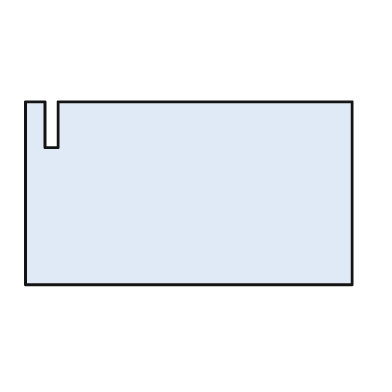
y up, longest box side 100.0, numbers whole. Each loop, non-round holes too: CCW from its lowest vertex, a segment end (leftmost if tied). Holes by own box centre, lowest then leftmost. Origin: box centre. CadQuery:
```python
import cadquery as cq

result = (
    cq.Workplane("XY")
    .moveTo(-50.0, -28.0)
    .lineTo(50.0, -28.0)
    .lineTo(50.0, 28.0)
    .lineTo(-40.0, 28.0)
    .lineTo(-40.0, 14.0)
    .lineTo(-44.0, 14.0)
    .lineTo(-44.0, 28.0)
    .lineTo(-50.0, 28.0)
    .close()
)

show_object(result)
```